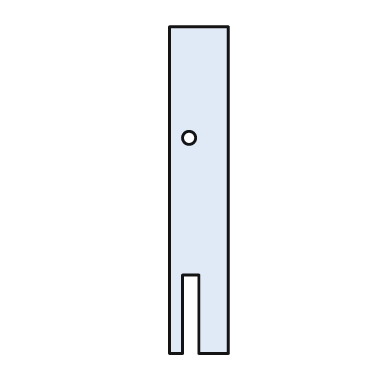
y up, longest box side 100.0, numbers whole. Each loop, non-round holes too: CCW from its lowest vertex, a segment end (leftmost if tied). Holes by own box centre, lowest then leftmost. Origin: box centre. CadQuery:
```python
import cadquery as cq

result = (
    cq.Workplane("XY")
    .moveTo(-9.0, -50.0)
    .lineTo(-5.0, -50.0)
    .lineTo(-5.0, -26.0)
    .lineTo(0.0, -26.0)
    .lineTo(0.0, -50.0)
    .lineTo(9.0, -50.0)
    .lineTo(9.0, 50.0)
    .lineTo(-9.0, 50.0)
    .close()
    .moveTo(-3.0, 16.0)
    .circle(2.0)
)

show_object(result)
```